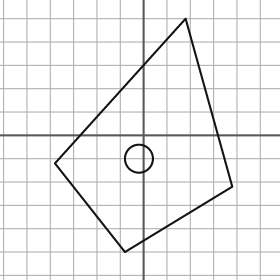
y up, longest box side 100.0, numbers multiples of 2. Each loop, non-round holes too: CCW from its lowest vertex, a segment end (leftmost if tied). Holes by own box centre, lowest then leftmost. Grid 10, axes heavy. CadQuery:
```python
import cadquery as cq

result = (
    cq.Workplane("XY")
    .moveTo(-8.0, -50.0)
    .lineTo(38.0, -22.0)
    .lineTo(18.0, 50.0)
    .lineTo(-38.0, -12.0)
    .close()
    .moveTo(-2.0, -10.0)
    .circle(6.0)
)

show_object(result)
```